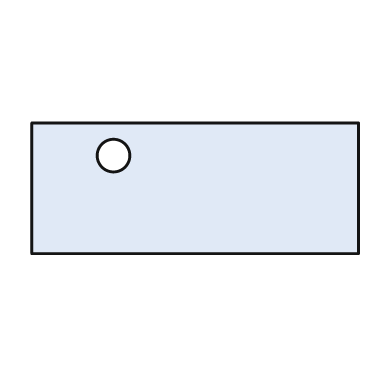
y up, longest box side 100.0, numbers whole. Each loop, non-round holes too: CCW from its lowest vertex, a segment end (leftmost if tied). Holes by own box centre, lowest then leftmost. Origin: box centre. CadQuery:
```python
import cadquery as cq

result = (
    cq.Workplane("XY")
    .moveTo(-50.0, -20.0)
    .lineTo(50.0, -20.0)
    .lineTo(50.0, 20.0)
    .lineTo(-50.0, 20.0)
    .close()
    .moveTo(-25.0, 10.0)
    .circle(5.0)
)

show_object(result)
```